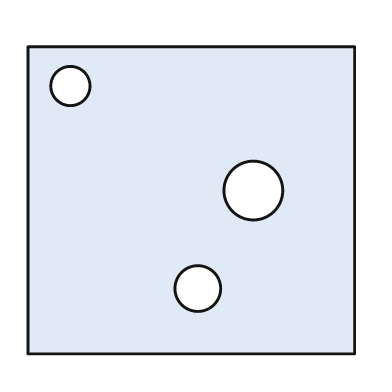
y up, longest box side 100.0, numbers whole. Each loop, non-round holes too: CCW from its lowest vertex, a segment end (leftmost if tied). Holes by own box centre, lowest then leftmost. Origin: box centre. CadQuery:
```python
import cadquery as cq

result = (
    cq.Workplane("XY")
    .moveTo(-50.0, -47.0)
    .lineTo(50.0, -47.0)
    .lineTo(50.0, 47.0)
    .lineTo(-50.0, 47.0)
    .close()
    .moveTo(2.0, -27.0)
    .circle(7.0)
    .moveTo(19.0, 3.0)
    .circle(9.0)
    .moveTo(-37.0, 35.0)
    .circle(6.0)
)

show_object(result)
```